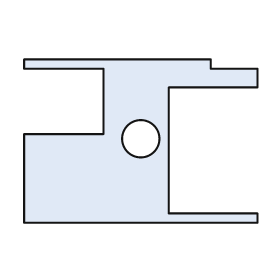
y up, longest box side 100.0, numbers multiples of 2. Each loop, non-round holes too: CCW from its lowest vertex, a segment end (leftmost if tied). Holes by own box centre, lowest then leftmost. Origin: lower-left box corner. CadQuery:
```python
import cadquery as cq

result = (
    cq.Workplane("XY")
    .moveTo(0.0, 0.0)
    .lineTo(100.0, 0.0)
    .lineTo(100.0, 4.0)
    .lineTo(62.0, 4.0)
    .lineTo(62.0, 58.0)
    .lineTo(100.0, 58.0)
    .lineTo(100.0, 66.0)
    .lineTo(80.0, 66.0)
    .lineTo(80.0, 70.0)
    .lineTo(0.0, 70.0)
    .lineTo(0.0, 66.0)
    .lineTo(34.0, 66.0)
    .lineTo(34.0, 38.0)
    .lineTo(0.0, 38.0)
    .close()
    .moveTo(50.0, 36.0)
    .circle(8.0)
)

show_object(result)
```